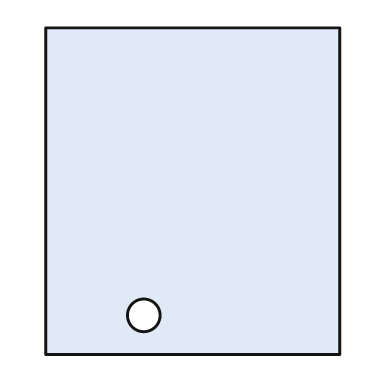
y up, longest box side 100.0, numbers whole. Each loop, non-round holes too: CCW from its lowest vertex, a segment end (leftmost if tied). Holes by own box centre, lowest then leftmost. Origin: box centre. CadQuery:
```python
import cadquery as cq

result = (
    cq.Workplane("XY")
    .moveTo(-45.0, -50.0)
    .lineTo(45.0, -50.0)
    .lineTo(45.0, 50.0)
    .lineTo(-45.0, 50.0)
    .close()
    .moveTo(-15.0, -38.0)
    .circle(5.0)
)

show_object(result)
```